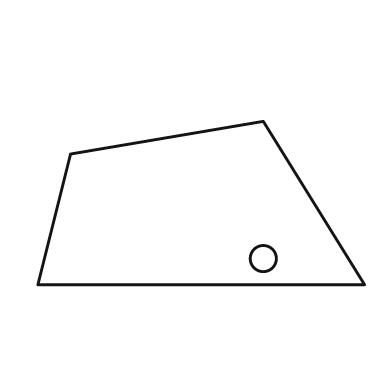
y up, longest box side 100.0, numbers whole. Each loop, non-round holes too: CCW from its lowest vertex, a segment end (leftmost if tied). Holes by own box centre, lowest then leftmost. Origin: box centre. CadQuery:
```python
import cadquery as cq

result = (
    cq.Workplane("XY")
    .moveTo(-50.0, -25.0)
    .lineTo(50.0, -25.0)
    .lineTo(19.0, 25.0)
    .lineTo(-40.0, 15.0)
    .close()
    .moveTo(19.0, -17.0)
    .circle(4.0)
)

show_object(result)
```